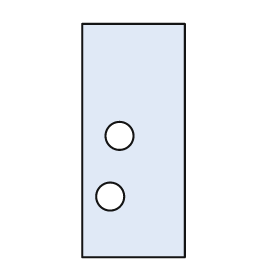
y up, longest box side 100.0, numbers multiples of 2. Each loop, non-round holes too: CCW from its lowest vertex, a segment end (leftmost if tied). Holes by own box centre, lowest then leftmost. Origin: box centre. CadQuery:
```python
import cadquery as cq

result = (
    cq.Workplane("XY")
    .moveTo(-22.0, -50.0)
    .lineTo(22.0, -50.0)
    .lineTo(22.0, 50.0)
    .lineTo(-22.0, 50.0)
    .close()
    .moveTo(-10.0, -24.0)
    .circle(6.0)
    .moveTo(-6.0, 2.0)
    .circle(6.0)
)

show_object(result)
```